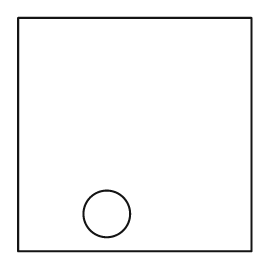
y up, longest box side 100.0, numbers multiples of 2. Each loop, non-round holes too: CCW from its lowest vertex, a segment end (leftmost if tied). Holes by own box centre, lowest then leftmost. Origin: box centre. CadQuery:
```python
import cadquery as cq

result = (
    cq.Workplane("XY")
    .moveTo(-50.0, -50.0)
    .lineTo(50.0, -50.0)
    .lineTo(50.0, 50.0)
    .lineTo(-50.0, 50.0)
    .close()
    .moveTo(-12.0, -34.0)
    .circle(10.0)
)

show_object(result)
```